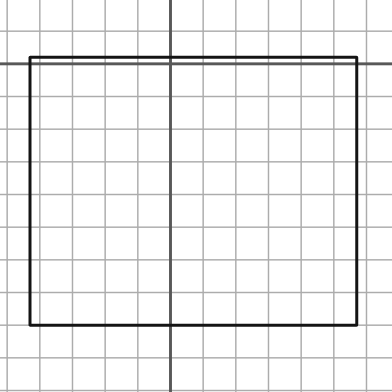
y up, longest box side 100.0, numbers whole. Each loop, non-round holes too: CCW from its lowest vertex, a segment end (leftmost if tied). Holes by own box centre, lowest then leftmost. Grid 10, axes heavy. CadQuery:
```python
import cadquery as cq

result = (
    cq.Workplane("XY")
    .moveTo(-43.0, -80.0)
    .lineTo(57.0, -80.0)
    .lineTo(57.0, 2.0)
    .lineTo(-43.0, 2.0)
    .close()
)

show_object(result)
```